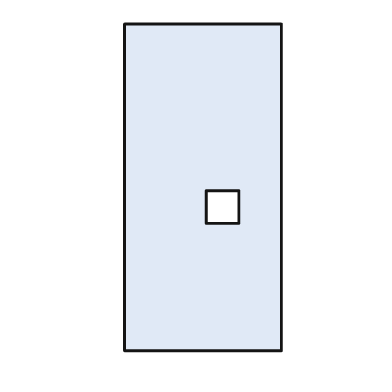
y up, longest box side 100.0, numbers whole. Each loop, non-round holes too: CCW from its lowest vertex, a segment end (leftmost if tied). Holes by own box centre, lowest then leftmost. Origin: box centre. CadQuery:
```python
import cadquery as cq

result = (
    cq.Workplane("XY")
    .moveTo(-24.0, -50.0)
    .lineTo(24.0, -50.0)
    .lineTo(24.0, 50.0)
    .lineTo(-24.0, 50.0)
    .close()
    .moveTo(1.0, -11.0)
    .lineTo(11.0, -11.0)
    .lineTo(11.0, -1.0)
    .lineTo(1.0, -1.0)
    .close()
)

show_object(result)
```